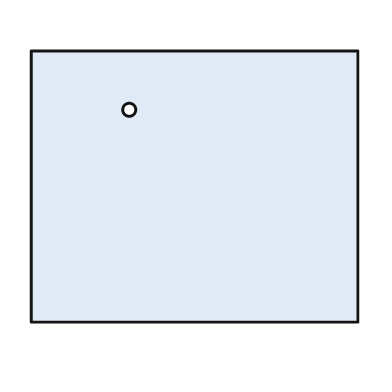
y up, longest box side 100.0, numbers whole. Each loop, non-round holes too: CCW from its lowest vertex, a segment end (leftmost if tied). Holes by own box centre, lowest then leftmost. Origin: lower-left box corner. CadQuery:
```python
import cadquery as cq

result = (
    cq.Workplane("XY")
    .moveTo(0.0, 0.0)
    .lineTo(100.0, 0.0)
    .lineTo(100.0, 83.0)
    .lineTo(0.0, 83.0)
    .close()
    .moveTo(30.0, 65.0)
    .circle(2.0)
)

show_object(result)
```